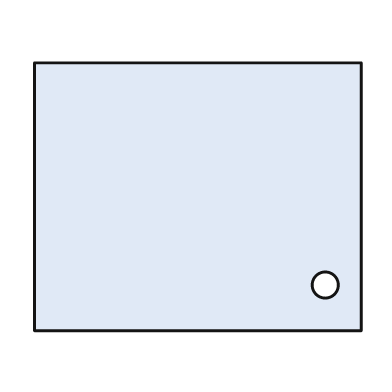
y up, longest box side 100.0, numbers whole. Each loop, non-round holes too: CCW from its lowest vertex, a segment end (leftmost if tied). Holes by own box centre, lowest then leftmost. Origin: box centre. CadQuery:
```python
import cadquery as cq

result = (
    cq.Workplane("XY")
    .moveTo(-50.0, -41.0)
    .lineTo(50.0, -41.0)
    .lineTo(50.0, 41.0)
    .lineTo(-50.0, 41.0)
    .close()
    .moveTo(39.0, -27.0)
    .circle(4.0)
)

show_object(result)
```